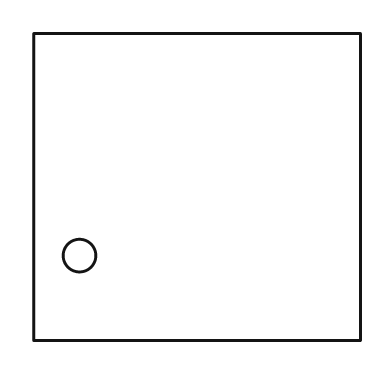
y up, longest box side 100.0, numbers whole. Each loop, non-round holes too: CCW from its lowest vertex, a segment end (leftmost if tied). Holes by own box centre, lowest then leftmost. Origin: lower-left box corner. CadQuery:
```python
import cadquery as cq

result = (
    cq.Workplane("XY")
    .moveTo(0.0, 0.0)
    .lineTo(100.0, 0.0)
    .lineTo(100.0, 94.0)
    .lineTo(0.0, 94.0)
    .close()
    .moveTo(14.0, 26.0)
    .circle(5.0)
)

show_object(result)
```